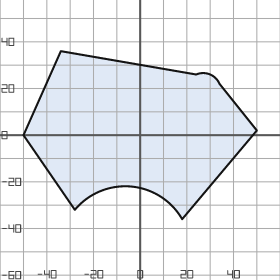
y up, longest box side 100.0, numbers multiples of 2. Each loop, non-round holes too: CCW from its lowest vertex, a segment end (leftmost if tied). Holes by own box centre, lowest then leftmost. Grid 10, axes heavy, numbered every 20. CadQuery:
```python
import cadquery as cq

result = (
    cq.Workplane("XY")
    .moveTo(18.0, -36.0)
    .lineTo(50.0, 2.0)
    .lineTo(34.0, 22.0)
    .threePointArc((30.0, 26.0), (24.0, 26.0))
    .lineTo(-34.0, 36.0)
    .lineTo(-50.0, 0.0)
    .lineTo(-28.0, -32.0)
    .threePointArc((-4.0, -22.0), (18.0, -36.0))
    .close()
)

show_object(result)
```